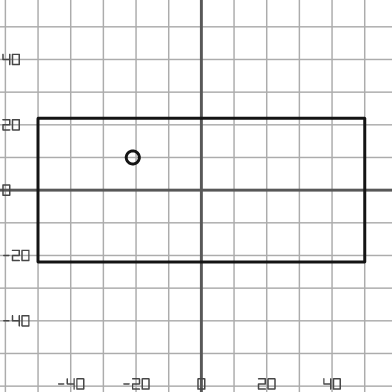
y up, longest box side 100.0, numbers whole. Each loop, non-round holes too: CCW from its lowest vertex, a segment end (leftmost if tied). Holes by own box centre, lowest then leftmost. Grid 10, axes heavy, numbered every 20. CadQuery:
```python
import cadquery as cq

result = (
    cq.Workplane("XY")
    .moveTo(-50.0, -22.0)
    .lineTo(50.0, -22.0)
    .lineTo(50.0, 22.0)
    .lineTo(-50.0, 22.0)
    .close()
    .moveTo(-21.0, 10.0)
    .circle(2.0)
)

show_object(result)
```